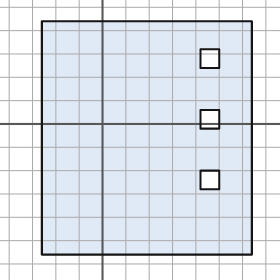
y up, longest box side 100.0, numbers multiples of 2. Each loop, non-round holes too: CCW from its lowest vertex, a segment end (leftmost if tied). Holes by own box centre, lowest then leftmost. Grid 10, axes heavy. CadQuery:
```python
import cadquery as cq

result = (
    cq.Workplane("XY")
    .moveTo(-26.0, -56.0)
    .lineTo(64.0, -56.0)
    .lineTo(64.0, 44.0)
    .lineTo(-26.0, 44.0)
    .close()
    .moveTo(42.0, -28.0)
    .lineTo(50.0, -28.0)
    .lineTo(50.0, -20.0)
    .lineTo(42.0, -20.0)
    .close()
    .moveTo(42.0, -2.0)
    .lineTo(50.0, -2.0)
    .lineTo(50.0, 6.0)
    .lineTo(42.0, 6.0)
    .close()
    .moveTo(42.0, 24.0)
    .lineTo(50.0, 24.0)
    .lineTo(50.0, 32.0)
    .lineTo(42.0, 32.0)
    .close()
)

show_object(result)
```